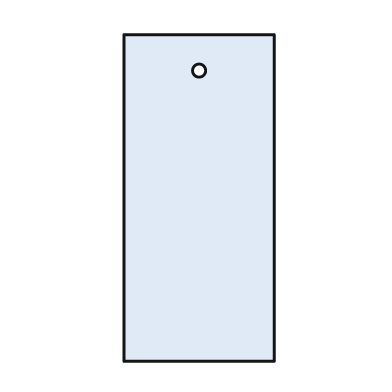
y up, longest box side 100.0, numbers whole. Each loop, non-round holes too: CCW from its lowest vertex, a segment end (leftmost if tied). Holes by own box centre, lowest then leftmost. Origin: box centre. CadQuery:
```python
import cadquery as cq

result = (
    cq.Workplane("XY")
    .moveTo(-23.0, -50.0)
    .lineTo(23.0, -50.0)
    .lineTo(23.0, 50.0)
    .lineTo(-23.0, 50.0)
    .close()
    .moveTo(0.0, 39.0)
    .circle(2.0)
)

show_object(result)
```